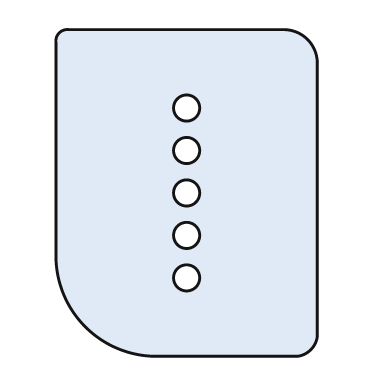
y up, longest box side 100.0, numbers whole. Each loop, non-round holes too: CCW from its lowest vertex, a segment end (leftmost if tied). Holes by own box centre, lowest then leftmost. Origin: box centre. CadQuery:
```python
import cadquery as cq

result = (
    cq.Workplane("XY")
    .moveTo(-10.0, -50.0)
    .lineTo(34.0, -50.0)
    .threePointArc((38.0, -48.0), (40.0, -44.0))
    .lineTo(40.0, 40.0)
    .threePointArc((37.0, 47.0), (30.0, 50.0))
    .lineTo(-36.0, 50.0)
    .threePointArc((-39.0, 49.0), (-40.0, 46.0))
    .lineTo(-40.0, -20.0)
    .threePointArc((-31.0, -41.0), (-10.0, -50.0))
    .close()
    .moveTo(0.0, -26.0)
    .circle(4.0)
    .moveTo(0.0, -13.0)
    .circle(4.0)
    .moveTo(0.0, 0.0)
    .circle(4.0)
    .moveTo(0.0, 13.0)
    .circle(4.0)
    .moveTo(0.0, 26.0)
    .circle(4.0)
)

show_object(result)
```